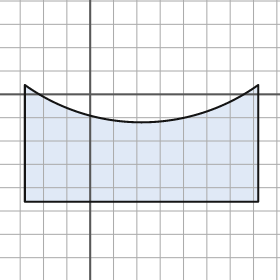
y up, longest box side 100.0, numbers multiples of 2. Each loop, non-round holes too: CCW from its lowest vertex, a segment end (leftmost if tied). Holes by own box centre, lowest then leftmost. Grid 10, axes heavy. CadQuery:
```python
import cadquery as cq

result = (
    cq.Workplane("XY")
    .moveTo(-28.0, -46.0)
    .lineTo(72.0, -46.0)
    .lineTo(72.0, 4.0)
    .threePointArc((22.0, -12.0), (-28.0, 4.0))
    .close()
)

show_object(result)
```